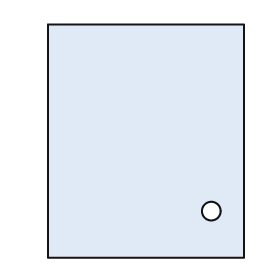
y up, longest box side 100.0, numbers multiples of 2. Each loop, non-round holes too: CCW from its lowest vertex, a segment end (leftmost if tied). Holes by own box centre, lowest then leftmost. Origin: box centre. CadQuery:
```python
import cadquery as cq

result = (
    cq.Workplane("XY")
    .moveTo(-42.0, -50.0)
    .lineTo(42.0, -50.0)
    .lineTo(42.0, 50.0)
    .lineTo(-42.0, 50.0)
    .close()
    .moveTo(28.0, -30.0)
    .circle(4.0)
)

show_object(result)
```